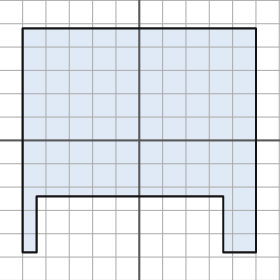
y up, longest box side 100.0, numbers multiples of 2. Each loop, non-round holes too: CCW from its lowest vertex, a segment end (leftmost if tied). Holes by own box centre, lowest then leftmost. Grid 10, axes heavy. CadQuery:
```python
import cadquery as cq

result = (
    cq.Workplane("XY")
    .moveTo(-50.0, -48.0)
    .lineTo(-44.0, -48.0)
    .lineTo(-44.0, -24.0)
    .lineTo(36.0, -24.0)
    .lineTo(36.0, -48.0)
    .lineTo(50.0, -48.0)
    .lineTo(50.0, 48.0)
    .lineTo(-50.0, 48.0)
    .close()
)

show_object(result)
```